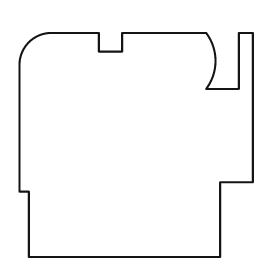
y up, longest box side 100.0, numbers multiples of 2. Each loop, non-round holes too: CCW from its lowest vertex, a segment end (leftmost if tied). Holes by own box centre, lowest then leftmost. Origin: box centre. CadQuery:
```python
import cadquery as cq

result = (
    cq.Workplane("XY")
    .moveTo(-46.0, -48.0)
    .lineTo(36.0, -48.0)
    .lineTo(36.0, -16.0)
    .lineTo(50.0, -16.0)
    .lineTo(50.0, 48.0)
    .lineTo(44.0, 48.0)
    .lineTo(44.0, 24.0)
    .lineTo(30.0, 24.0)
    .threePointArc((34.0, 36.0), (30.0, 48.0))
    .lineTo(-6.0, 48.0)
    .lineTo(-6.0, 40.0)
    .lineTo(-16.0, 40.0)
    .lineTo(-16.0, 48.0)
    .lineTo(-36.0, 48.0)
    .threePointArc((-46.0, 44.0), (-50.0, 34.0))
    .lineTo(-50.0, -20.0)
    .lineTo(-46.0, -20.0)
    .close()
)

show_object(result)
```